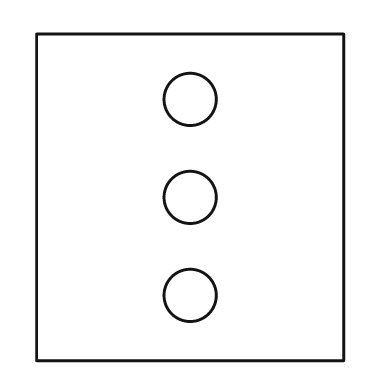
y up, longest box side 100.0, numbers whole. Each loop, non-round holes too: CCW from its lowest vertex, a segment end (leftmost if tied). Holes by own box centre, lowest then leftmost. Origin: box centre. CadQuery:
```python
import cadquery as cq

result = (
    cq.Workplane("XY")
    .moveTo(-47.0, -50.0)
    .lineTo(47.0, -50.0)
    .lineTo(47.0, 50.0)
    .lineTo(-47.0, 50.0)
    .close()
    .moveTo(0.0, -30.0)
    .circle(8.0)
    .moveTo(0.0, 0.0)
    .circle(8.0)
    .moveTo(0.0, 30.0)
    .circle(8.0)
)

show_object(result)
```